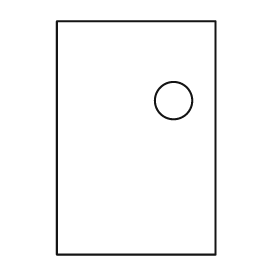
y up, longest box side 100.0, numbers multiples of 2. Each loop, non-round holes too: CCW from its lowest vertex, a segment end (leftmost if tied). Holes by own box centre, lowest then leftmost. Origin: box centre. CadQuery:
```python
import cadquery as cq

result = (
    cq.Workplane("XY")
    .moveTo(-34.0, -50.0)
    .lineTo(34.0, -50.0)
    .lineTo(34.0, 50.0)
    .lineTo(-34.0, 50.0)
    .close()
    .moveTo(16.0, 16.0)
    .circle(8.0)
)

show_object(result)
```